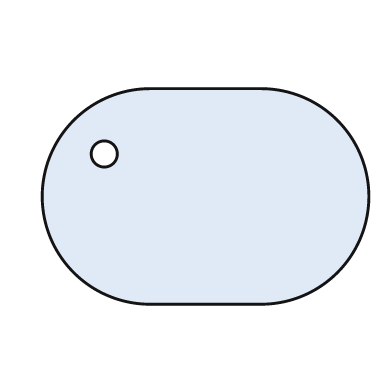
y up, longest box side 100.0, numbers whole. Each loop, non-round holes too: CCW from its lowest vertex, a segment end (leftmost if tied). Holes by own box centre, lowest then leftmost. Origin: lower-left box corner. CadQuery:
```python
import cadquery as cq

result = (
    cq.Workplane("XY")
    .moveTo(33.0, 0.0)
    .lineTo(67.0, 0.0)
    .threePointArc((100.0, 33.0), (67.0, 66.0))
    .lineTo(33.0, 66.0)
    .threePointArc((0.0, 33.0), (33.0, 0.0))
    .close()
    .moveTo(19.0, 46.0)
    .circle(4.0)
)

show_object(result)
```